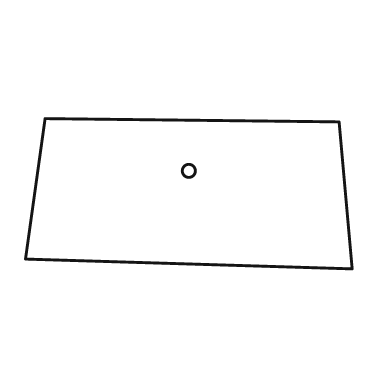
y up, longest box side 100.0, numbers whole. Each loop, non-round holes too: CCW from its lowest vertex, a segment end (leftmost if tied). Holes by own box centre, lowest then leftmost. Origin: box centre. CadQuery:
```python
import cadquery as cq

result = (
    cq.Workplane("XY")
    .moveTo(50.0, -23.0)
    .lineTo(46.0, 22.0)
    .lineTo(-44.0, 23.0)
    .lineTo(-50.0, -20.0)
    .close()
    .moveTo(0.0, 7.0)
    .circle(2.0)
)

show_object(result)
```